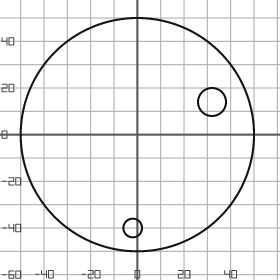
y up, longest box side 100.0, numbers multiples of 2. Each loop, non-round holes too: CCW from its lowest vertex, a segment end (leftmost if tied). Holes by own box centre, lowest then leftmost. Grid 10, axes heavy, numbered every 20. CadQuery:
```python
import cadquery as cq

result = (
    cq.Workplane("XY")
    .moveTo(0.0, 0.0)
    .circle(50.0)
    .moveTo(-2.0, -40.0)
    .circle(4.0)
    .moveTo(32.0, 14.0)
    .circle(6.0)
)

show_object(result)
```